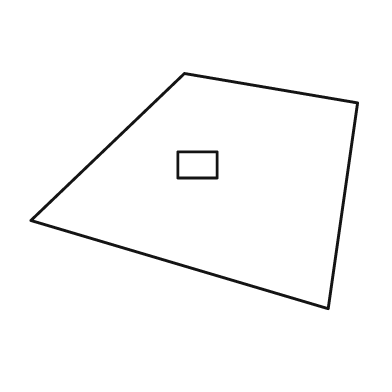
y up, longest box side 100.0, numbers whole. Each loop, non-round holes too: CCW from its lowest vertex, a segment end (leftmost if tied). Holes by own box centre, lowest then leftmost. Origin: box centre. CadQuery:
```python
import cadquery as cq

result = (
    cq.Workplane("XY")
    .moveTo(41.0, -36.0)
    .lineTo(50.0, 27.0)
    .lineTo(-3.0, 36.0)
    .lineTo(-50.0, -9.0)
    .close()
    .moveTo(-5.0, 4.0)
    .lineTo(7.0, 4.0)
    .lineTo(7.0, 12.0)
    .lineTo(-5.0, 12.0)
    .close()
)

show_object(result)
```